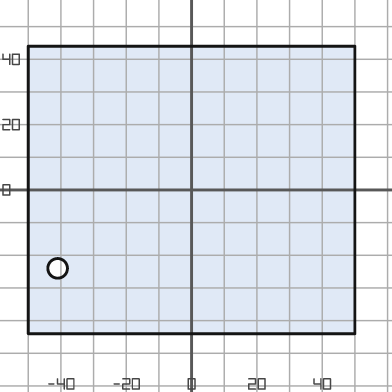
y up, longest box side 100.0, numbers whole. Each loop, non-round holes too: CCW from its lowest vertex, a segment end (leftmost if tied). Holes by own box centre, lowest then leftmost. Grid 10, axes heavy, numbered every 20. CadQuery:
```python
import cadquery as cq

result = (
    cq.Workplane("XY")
    .moveTo(-50.0, -44.0)
    .lineTo(50.0, -44.0)
    .lineTo(50.0, 44.0)
    .lineTo(-50.0, 44.0)
    .close()
    .moveTo(-41.0, -24.0)
    .circle(3.0)
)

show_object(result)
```